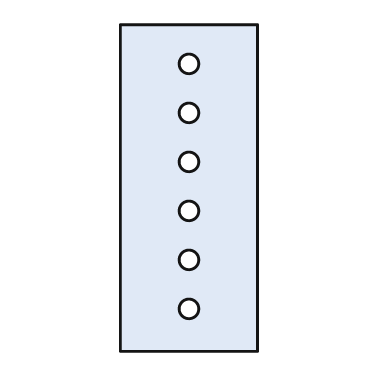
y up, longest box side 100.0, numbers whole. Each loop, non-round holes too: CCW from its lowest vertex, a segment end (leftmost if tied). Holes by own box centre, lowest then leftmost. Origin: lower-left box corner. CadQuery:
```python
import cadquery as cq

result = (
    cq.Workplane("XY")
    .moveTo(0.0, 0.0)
    .lineTo(42.0, 0.0)
    .lineTo(42.0, 100.0)
    .lineTo(0.0, 100.0)
    .close()
    .moveTo(21.0, 13.0)
    .circle(3.0)
    .moveTo(21.0, 28.0)
    .circle(3.0)
    .moveTo(21.0, 43.0)
    .circle(3.0)
    .moveTo(21.0, 58.0)
    .circle(3.0)
    .moveTo(21.0, 73.0)
    .circle(3.0)
    .moveTo(21.0, 88.0)
    .circle(3.0)
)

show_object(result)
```